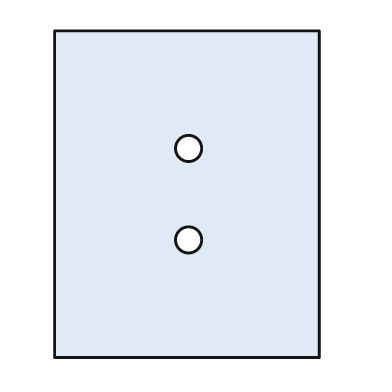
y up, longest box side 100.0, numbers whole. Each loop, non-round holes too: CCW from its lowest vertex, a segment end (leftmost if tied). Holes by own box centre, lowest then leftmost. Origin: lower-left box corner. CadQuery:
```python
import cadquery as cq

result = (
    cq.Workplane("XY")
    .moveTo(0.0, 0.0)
    .lineTo(81.0, 0.0)
    .lineTo(81.0, 100.0)
    .lineTo(0.0, 100.0)
    .close()
    .moveTo(41.0, 36.0)
    .circle(4.0)
    .moveTo(41.0, 64.0)
    .circle(4.0)
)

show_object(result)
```